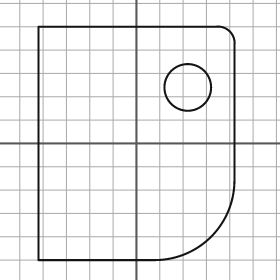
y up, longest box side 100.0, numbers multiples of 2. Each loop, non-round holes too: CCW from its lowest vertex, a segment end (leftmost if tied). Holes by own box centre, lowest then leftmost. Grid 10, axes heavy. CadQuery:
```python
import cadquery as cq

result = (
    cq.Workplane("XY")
    .moveTo(-42.0, -50.0)
    .lineTo(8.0, -50.0)
    .threePointArc((32.0, -40.0), (42.0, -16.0))
    .lineTo(42.0, 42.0)
    .threePointArc((40.0, 48.0), (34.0, 50.0))
    .lineTo(-42.0, 50.0)
    .close()
    .moveTo(22.0, 24.0)
    .circle(10.0)
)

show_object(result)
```